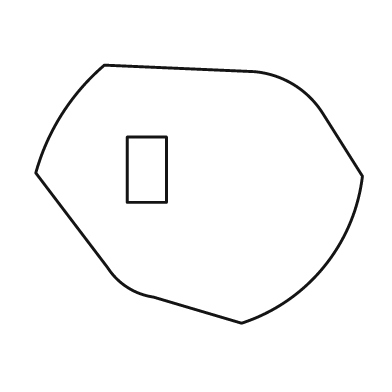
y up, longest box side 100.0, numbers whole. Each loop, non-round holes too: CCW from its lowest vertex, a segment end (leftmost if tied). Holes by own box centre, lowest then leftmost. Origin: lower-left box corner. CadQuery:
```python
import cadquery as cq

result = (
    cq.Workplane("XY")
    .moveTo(63.0, 0.0)
    .threePointArc((88.0, 17.0), (100.0, 45.0))
    .lineTo(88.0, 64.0)
    .threePointArc((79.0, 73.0), (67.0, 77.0))
    .lineTo(21.0, 79.0)
    .threePointArc((8.0, 64.0), (0.0, 46.0))
    .lineTo(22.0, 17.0)
    .threePointArc((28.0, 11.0), (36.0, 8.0))
    .close()
    .moveTo(28.0, 37.0)
    .lineTo(40.0, 37.0)
    .lineTo(40.0, 57.0)
    .lineTo(28.0, 57.0)
    .close()
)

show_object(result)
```